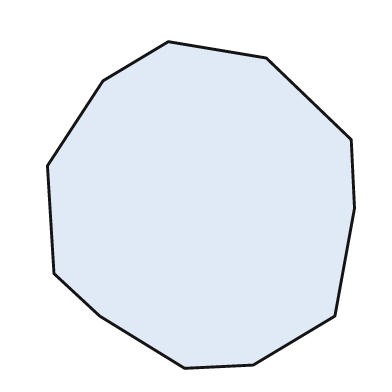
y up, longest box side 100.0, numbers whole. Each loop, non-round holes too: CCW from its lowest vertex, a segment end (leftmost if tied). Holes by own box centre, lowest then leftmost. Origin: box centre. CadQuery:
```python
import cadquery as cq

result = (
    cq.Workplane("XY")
    .moveTo(-5.0, -50.0)
    .lineTo(16.0, -49.0)
    .lineTo(41.0, -34.0)
    .lineTo(47.0, -1.0)
    .lineTo(46.0, 20.0)
    .lineTo(20.0, 45.0)
    .lineTo(-10.0, 50.0)
    .lineTo(-30.0, 38.0)
    .lineTo(-47.0, 12.0)
    .lineTo(-45.0, -21.0)
    .lineTo(-31.0, -34.0)
    .close()
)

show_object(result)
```